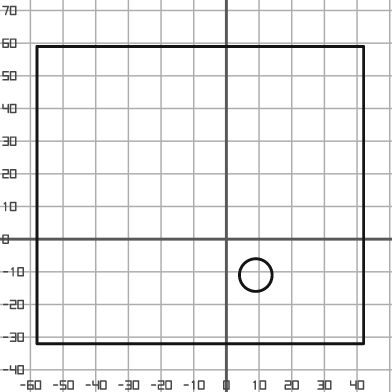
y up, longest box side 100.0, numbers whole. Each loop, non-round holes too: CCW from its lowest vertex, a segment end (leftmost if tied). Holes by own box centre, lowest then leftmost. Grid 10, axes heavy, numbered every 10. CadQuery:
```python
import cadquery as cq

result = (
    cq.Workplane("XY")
    .moveTo(-58.0, -32.0)
    .lineTo(42.0, -32.0)
    .lineTo(42.0, 59.0)
    .lineTo(-58.0, 59.0)
    .close()
    .moveTo(9.0, -11.0)
    .circle(5.0)
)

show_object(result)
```